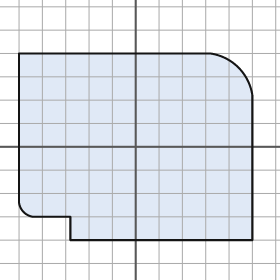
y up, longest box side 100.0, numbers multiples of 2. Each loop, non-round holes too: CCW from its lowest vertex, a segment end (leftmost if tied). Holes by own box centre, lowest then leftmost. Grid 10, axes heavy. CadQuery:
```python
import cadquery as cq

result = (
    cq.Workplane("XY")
    .moveTo(-28.0, -40.0)
    .lineTo(50.0, -40.0)
    .lineTo(50.0, 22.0)
    .threePointArc((44.0, 34.0), (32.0, 40.0))
    .lineTo(-50.0, 40.0)
    .lineTo(-50.0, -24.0)
    .threePointArc((-48.0, -28.0), (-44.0, -30.0))
    .lineTo(-28.0, -30.0)
    .close()
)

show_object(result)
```